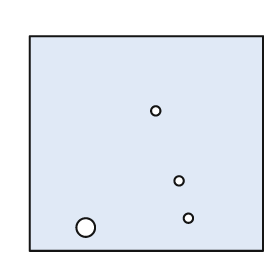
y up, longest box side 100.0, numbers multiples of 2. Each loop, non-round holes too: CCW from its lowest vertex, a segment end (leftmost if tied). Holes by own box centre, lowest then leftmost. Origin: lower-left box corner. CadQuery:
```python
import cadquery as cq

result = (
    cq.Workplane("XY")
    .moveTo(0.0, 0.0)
    .lineTo(100.0, 0.0)
    .lineTo(100.0, 92.0)
    .lineTo(0.0, 92.0)
    .close()
    .moveTo(24.0, 10.0)
    .circle(4.0)
    .moveTo(68.0, 14.0)
    .circle(2.0)
    .moveTo(64.0, 30.0)
    .circle(2.0)
    .moveTo(54.0, 60.0)
    .circle(2.0)
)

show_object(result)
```